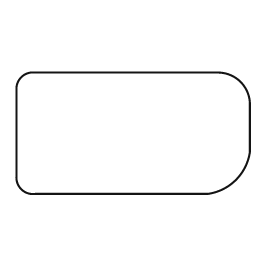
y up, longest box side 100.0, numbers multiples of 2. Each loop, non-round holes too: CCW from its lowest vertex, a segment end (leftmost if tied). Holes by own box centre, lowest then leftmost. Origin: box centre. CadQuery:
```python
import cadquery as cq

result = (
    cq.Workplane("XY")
    .moveTo(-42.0, -26.0)
    .lineTo(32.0, -26.0)
    .threePointArc((44.0, -20.0), (50.0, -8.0))
    .lineTo(50.0, 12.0)
    .threePointArc((46.0, 22.0), (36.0, 26.0))
    .lineTo(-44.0, 26.0)
    .threePointArc((-48.0, 24.0), (-50.0, 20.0))
    .lineTo(-50.0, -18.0)
    .threePointArc((-48.0, -24.0), (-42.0, -26.0))
    .close()
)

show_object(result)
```